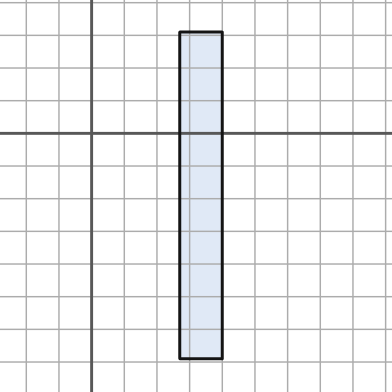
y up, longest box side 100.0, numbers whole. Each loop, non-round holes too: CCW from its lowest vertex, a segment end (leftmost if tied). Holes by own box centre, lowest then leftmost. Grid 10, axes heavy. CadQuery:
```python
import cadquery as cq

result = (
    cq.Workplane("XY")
    .moveTo(27.0, -69.0)
    .lineTo(40.0, -69.0)
    .lineTo(40.0, 31.0)
    .lineTo(27.0, 31.0)
    .close()
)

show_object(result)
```